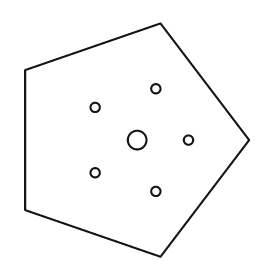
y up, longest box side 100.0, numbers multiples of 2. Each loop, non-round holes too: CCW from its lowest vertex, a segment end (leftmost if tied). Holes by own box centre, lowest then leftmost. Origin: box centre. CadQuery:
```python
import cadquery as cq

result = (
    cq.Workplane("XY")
    .moveTo(10.0, -50.0)
    .lineTo(48.0, 0.0)
    .lineTo(10.0, 50.0)
    .lineTo(-48.0, 30.0)
    .lineTo(-48.0, -30.0)
    .close()
    .moveTo(8.0, -22.0)
    .circle(2.0)
    .moveTo(-18.0, -14.0)
    .circle(2.0)
    .moveTo(0.0, 0.0)
    .circle(4.0)
    .moveTo(22.0, 0.0)
    .circle(2.0)
    .moveTo(-18.0, 14.0)
    .circle(2.0)
    .moveTo(8.0, 22.0)
    .circle(2.0)
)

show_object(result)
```